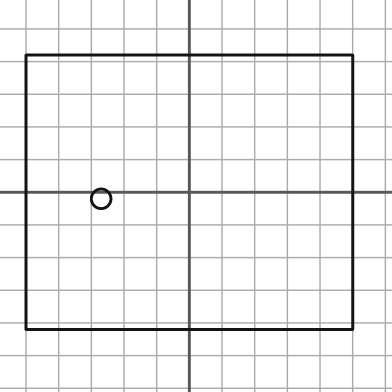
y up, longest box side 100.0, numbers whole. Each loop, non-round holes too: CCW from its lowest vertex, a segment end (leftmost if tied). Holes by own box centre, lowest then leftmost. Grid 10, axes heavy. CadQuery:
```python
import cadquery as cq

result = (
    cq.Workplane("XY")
    .moveTo(-50.0, -42.0)
    .lineTo(50.0, -42.0)
    .lineTo(50.0, 42.0)
    .lineTo(-50.0, 42.0)
    .close()
    .moveTo(-27.0, -2.0)
    .circle(3.0)
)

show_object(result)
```